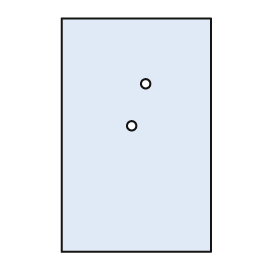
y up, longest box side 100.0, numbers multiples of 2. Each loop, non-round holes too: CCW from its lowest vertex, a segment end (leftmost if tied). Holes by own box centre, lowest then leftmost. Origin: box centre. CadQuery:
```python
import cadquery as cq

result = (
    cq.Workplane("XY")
    .moveTo(-32.0, -50.0)
    .lineTo(32.0, -50.0)
    .lineTo(32.0, 50.0)
    .lineTo(-32.0, 50.0)
    .close()
    .moveTo(-2.0, 4.0)
    .circle(2.0)
    .moveTo(4.0, 22.0)
    .circle(2.0)
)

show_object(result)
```